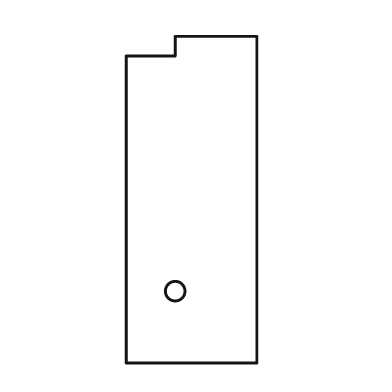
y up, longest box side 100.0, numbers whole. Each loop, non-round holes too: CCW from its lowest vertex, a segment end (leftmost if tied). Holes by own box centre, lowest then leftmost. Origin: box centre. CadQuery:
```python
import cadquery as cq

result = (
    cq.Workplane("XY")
    .moveTo(-20.0, -50.0)
    .lineTo(20.0, -50.0)
    .lineTo(20.0, 50.0)
    .lineTo(-5.0, 50.0)
    .lineTo(-5.0, 44.0)
    .lineTo(-20.0, 44.0)
    .close()
    .moveTo(-5.0, -28.0)
    .circle(3.0)
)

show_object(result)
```